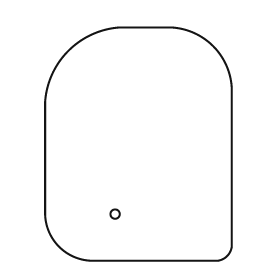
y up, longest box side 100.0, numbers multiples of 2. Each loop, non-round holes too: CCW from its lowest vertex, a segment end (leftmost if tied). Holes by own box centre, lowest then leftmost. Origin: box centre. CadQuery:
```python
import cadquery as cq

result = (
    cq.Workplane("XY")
    .moveTo(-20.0, -50.0)
    .lineTo(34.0, -50.0)
    .threePointArc((38.0, -48.0), (40.0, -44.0))
    .lineTo(40.0, 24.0)
    .threePointArc((32.0, 42.0), (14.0, 50.0))
    .lineTo(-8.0, 50.0)
    .threePointArc((-30.0, 40.0), (-40.0, 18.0))
    .lineTo(-40.0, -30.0)
    .threePointArc((-34.0, -44.0), (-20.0, -50.0))
    .close()
    .moveTo(-10.0, -30.0)
    .circle(2.0)
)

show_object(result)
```